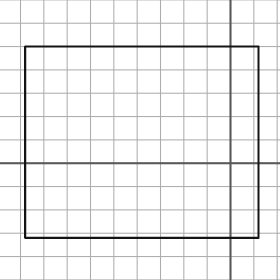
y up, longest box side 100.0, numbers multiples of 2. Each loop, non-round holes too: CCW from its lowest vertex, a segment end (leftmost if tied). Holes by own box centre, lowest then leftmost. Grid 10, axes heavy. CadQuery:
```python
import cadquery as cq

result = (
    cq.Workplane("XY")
    .moveTo(-88.0, -32.0)
    .lineTo(12.0, -32.0)
    .lineTo(12.0, 50.0)
    .lineTo(-88.0, 50.0)
    .close()
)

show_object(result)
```